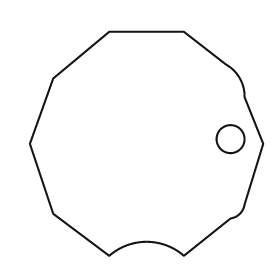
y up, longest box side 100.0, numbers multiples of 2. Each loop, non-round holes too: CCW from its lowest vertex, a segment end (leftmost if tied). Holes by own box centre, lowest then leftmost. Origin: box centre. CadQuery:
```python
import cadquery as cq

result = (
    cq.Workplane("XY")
    .moveTo(-16.0, -48.0)
    .threePointArc((0.0, -42.0), (16.0, -48.0))
    .lineTo(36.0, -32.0)
    .threePointArc((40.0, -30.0), (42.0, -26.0))
    .lineTo(50.0, 0.0)
    .lineTo(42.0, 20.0)
    .threePointArc((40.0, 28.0), (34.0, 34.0))
    .lineTo(16.0, 48.0)
    .lineTo(-16.0, 48.0)
    .lineTo(-40.0, 28.0)
    .lineTo(-50.0, 0.0)
    .lineTo(-40.0, -30.0)
    .close()
    .moveTo(36.0, 2.0)
    .circle(6.0)
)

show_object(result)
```